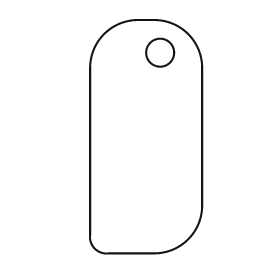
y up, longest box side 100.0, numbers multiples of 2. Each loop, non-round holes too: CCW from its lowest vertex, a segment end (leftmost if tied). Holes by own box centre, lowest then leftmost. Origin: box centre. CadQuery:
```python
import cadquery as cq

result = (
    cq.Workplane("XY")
    .moveTo(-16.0, -50.0)
    .lineTo(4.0, -50.0)
    .threePointArc((18.0, -44.0), (24.0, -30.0))
    .lineTo(24.0, 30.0)
    .threePointArc((18.0, 44.0), (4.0, 50.0))
    .lineTo(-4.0, 50.0)
    .threePointArc((-18.0, 44.0), (-24.0, 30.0))
    .lineTo(-24.0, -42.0)
    .threePointArc((-22.0, -48.0), (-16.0, -50.0))
    .close()
    .moveTo(6.0, 36.0)
    .circle(6.0)
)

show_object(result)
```